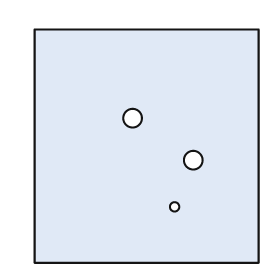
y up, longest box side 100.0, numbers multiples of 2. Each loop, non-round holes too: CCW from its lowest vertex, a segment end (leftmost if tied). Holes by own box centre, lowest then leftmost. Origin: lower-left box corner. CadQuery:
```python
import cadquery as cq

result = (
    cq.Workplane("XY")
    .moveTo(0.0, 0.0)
    .lineTo(96.0, 0.0)
    .lineTo(96.0, 100.0)
    .lineTo(0.0, 100.0)
    .close()
    .moveTo(60.0, 24.0)
    .circle(2.0)
    .moveTo(68.0, 44.0)
    .circle(4.0)
    .moveTo(42.0, 62.0)
    .circle(4.0)
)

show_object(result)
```